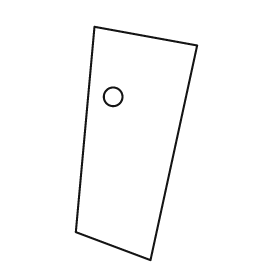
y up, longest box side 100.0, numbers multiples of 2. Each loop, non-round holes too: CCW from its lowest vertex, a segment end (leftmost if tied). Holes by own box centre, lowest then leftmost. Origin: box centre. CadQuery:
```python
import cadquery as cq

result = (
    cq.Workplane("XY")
    .moveTo(6.0, -50.0)
    .lineTo(26.0, 42.0)
    .lineTo(-18.0, 50.0)
    .lineTo(-26.0, -38.0)
    .close()
    .moveTo(-10.0, 20.0)
    .circle(4.0)
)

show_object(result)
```